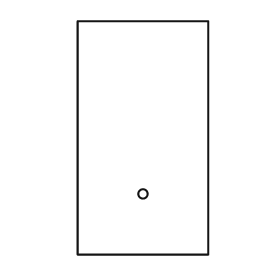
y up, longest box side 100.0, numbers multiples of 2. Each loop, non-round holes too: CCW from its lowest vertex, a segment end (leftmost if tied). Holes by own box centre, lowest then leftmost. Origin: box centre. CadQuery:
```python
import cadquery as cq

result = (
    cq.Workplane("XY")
    .moveTo(-28.0, -50.0)
    .lineTo(28.0, -50.0)
    .lineTo(28.0, 50.0)
    .lineTo(-28.0, 50.0)
    .close()
    .moveTo(0.0, -24.0)
    .circle(2.0)
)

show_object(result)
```